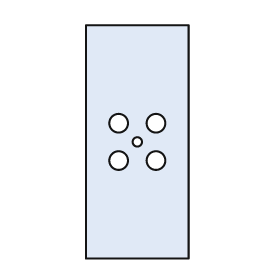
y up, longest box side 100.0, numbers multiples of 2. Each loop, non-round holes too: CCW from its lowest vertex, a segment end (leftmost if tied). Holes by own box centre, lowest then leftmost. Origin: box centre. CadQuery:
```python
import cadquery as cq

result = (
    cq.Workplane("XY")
    .moveTo(-22.0, -50.0)
    .lineTo(22.0, -50.0)
    .lineTo(22.0, 50.0)
    .lineTo(-22.0, 50.0)
    .close()
    .moveTo(-8.0, -8.0)
    .circle(4.0)
    .moveTo(8.0, -8.0)
    .circle(4.0)
    .moveTo(0.0, 0.0)
    .circle(2.0)
    .moveTo(-8.0, 8.0)
    .circle(4.0)
    .moveTo(8.0, 8.0)
    .circle(4.0)
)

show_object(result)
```